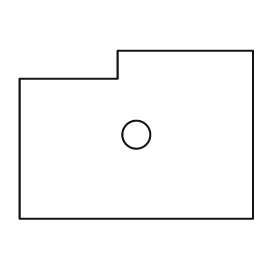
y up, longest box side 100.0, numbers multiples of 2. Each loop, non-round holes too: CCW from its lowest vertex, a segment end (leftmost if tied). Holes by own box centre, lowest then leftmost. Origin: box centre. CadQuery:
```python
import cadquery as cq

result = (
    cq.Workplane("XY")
    .moveTo(-50.0, -36.0)
    .lineTo(50.0, -36.0)
    .lineTo(50.0, 36.0)
    .lineTo(-8.0, 36.0)
    .lineTo(-8.0, 24.0)
    .lineTo(-50.0, 24.0)
    .close()
    .moveTo(0.0, 0.0)
    .circle(6.0)
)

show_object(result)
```